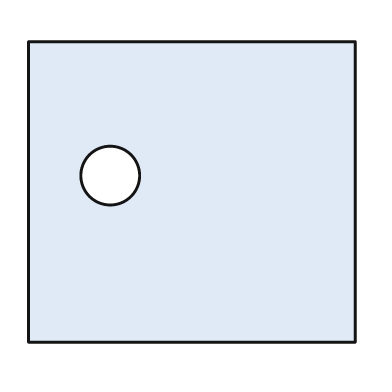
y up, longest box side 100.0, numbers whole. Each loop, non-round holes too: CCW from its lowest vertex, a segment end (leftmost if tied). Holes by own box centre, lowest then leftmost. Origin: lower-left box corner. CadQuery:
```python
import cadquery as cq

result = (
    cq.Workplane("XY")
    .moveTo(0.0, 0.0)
    .lineTo(100.0, 0.0)
    .lineTo(100.0, 92.0)
    .lineTo(0.0, 92.0)
    .close()
    .moveTo(25.0, 51.0)
    .circle(9.0)
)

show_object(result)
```